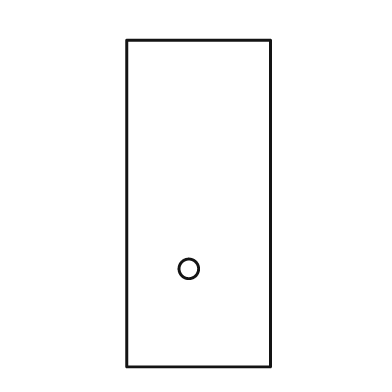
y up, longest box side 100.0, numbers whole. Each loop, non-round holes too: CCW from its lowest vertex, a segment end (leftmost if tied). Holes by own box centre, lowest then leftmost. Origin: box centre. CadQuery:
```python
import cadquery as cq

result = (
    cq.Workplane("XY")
    .moveTo(-22.0, -50.0)
    .lineTo(22.0, -50.0)
    .lineTo(22.0, 50.0)
    .lineTo(-22.0, 50.0)
    .close()
    .moveTo(-3.0, -20.0)
    .circle(3.0)
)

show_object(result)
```